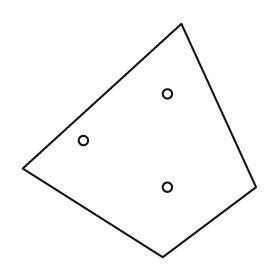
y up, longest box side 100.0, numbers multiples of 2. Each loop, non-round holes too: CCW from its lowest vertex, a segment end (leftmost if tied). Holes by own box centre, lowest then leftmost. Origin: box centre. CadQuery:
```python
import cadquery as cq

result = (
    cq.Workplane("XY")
    .moveTo(10.0, -50.0)
    .lineTo(50.0, -20.0)
    .lineTo(18.0, 50.0)
    .lineTo(-50.0, -12.0)
    .close()
    .moveTo(12.0, -20.0)
    .circle(2.0)
    .moveTo(-24.0, 0.0)
    .circle(2.0)
    .moveTo(12.0, 20.0)
    .circle(2.0)
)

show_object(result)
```